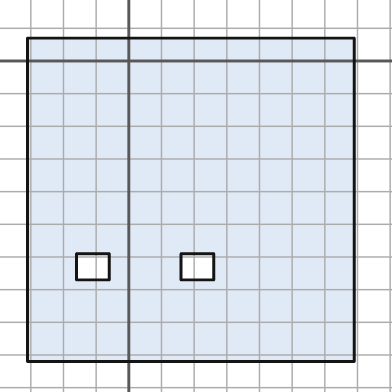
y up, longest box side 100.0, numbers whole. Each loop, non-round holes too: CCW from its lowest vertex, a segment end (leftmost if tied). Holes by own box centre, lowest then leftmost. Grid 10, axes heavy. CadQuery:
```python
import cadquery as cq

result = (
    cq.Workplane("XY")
    .moveTo(-31.0, -92.0)
    .lineTo(69.0, -92.0)
    .lineTo(69.0, 7.0)
    .lineTo(-31.0, 7.0)
    .close()
    .moveTo(-16.0, -67.0)
    .lineTo(-6.0, -67.0)
    .lineTo(-6.0, -59.0)
    .lineTo(-16.0, -59.0)
    .close()
    .moveTo(16.0, -67.0)
    .lineTo(26.0, -67.0)
    .lineTo(26.0, -59.0)
    .lineTo(16.0, -59.0)
    .close()
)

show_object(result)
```